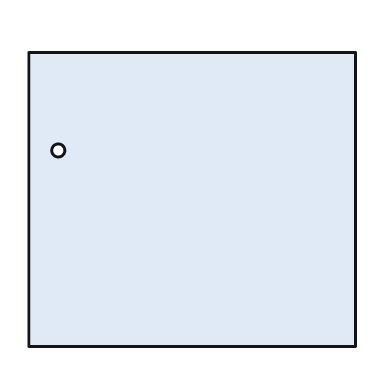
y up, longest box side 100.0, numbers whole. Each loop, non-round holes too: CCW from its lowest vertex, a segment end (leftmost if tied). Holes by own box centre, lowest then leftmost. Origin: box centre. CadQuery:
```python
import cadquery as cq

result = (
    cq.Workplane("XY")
    .moveTo(-50.0, -45.0)
    .lineTo(50.0, -45.0)
    .lineTo(50.0, 45.0)
    .lineTo(-50.0, 45.0)
    .close()
    .moveTo(-41.0, 15.0)
    .circle(2.0)
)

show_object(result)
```